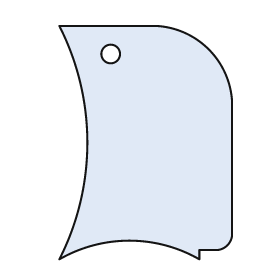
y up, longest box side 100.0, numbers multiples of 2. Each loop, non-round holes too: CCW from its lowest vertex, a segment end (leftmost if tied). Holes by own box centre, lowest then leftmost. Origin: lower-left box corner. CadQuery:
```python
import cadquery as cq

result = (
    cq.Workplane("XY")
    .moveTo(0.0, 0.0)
    .threePointArc((30.0, 8.0), (60.0, 0.0))
    .lineTo(60.0, 4.0)
    .lineTo(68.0, 4.0)
    .threePointArc((72.0, 6.0), (74.0, 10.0))
    .lineTo(74.0, 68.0)
    .threePointArc((64.0, 90.0), (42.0, 100.0))
    .lineTo(0.0, 100.0)
    .threePointArc((12.0, 50.0), (0.0, 0.0))
    .close()
    .moveTo(22.0, 88.0)
    .circle(4.0)
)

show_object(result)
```